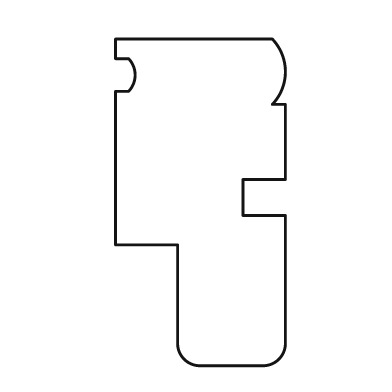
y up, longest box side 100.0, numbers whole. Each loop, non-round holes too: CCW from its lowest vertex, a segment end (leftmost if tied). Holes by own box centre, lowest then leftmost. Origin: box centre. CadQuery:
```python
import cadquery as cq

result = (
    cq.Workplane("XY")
    .moveTo(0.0, -50.0)
    .lineTo(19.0, -50.0)
    .threePointArc((24.0, -48.0), (26.0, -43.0))
    .lineTo(26.0, -4.0)
    .lineTo(13.0, -4.0)
    .lineTo(13.0, 7.0)
    .lineTo(26.0, 7.0)
    .lineTo(26.0, 30.0)
    .lineTo(22.0, 30.0)
    .threePointArc((26.0, 40.0), (22.0, 50.0))
    .lineTo(-26.0, 50.0)
    .lineTo(-26.0, 44.0)
    .lineTo(-22.0, 44.0)
    .threePointArc((-20.0, 39.0), (-22.0, 34.0))
    .lineTo(-26.0, 34.0)
    .lineTo(-26.0, -13.0)
    .lineTo(-7.0, -13.0)
    .lineTo(-7.0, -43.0)
    .threePointArc((-5.0, -48.0), (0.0, -50.0))
    .close()
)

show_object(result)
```